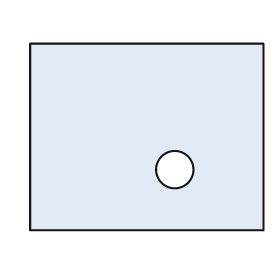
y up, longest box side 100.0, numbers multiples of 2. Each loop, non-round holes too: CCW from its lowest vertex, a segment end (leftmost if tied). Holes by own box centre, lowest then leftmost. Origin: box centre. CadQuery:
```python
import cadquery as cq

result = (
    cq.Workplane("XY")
    .moveTo(-50.0, -40.0)
    .lineTo(50.0, -40.0)
    .lineTo(50.0, 40.0)
    .lineTo(-50.0, 40.0)
    .close()
    .moveTo(12.0, -14.0)
    .circle(8.0)
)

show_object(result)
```